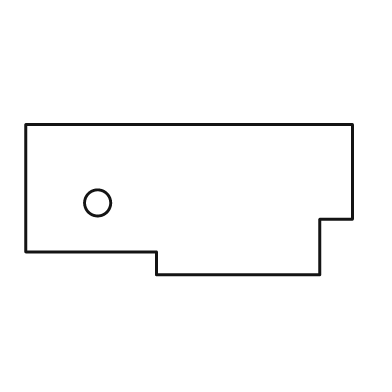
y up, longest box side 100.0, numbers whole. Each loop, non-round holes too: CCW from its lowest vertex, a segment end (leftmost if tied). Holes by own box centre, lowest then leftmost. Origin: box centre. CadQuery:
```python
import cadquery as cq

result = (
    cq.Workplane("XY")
    .moveTo(-10.0, -23.0)
    .lineTo(40.0, -23.0)
    .lineTo(40.0, -6.0)
    .lineTo(50.0, -6.0)
    .lineTo(50.0, 23.0)
    .lineTo(-50.0, 23.0)
    .lineTo(-50.0, -16.0)
    .lineTo(-10.0, -16.0)
    .close()
    .moveTo(-28.0, -1.0)
    .circle(4.0)
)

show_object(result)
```